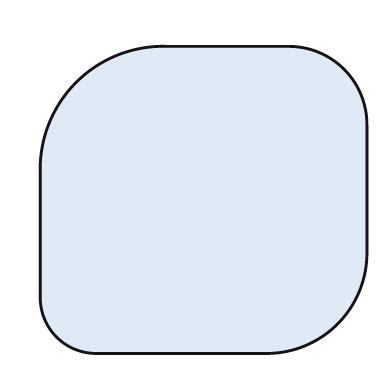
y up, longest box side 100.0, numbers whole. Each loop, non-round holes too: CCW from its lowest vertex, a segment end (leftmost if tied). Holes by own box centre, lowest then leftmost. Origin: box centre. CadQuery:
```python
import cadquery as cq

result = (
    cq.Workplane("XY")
    .moveTo(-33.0, -47.0)
    .lineTo(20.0, -47.0)
    .threePointArc((41.0, -38.0), (50.0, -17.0))
    .lineTo(50.0, 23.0)
    .threePointArc((43.0, 40.0), (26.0, 47.0))
    .lineTo(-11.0, 47.0)
    .threePointArc((-39.0, 36.0), (-50.0, 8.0))
    .lineTo(-50.0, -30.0)
    .threePointArc((-45.0, -42.0), (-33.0, -47.0))
    .close()
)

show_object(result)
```